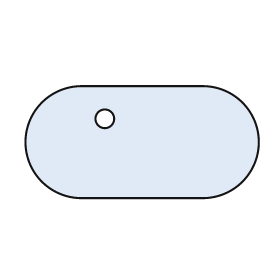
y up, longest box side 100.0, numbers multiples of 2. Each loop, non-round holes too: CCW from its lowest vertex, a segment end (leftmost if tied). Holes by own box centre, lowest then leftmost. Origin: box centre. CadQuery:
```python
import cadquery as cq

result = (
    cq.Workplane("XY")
    .moveTo(-26.0, -24.0)
    .lineTo(26.0, -24.0)
    .threePointArc((50.0, 0.0), (26.0, 24.0))
    .lineTo(-26.0, 24.0)
    .threePointArc((-50.0, 0.0), (-26.0, -24.0))
    .close()
    .moveTo(-16.0, 10.0)
    .circle(4.0)
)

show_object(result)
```